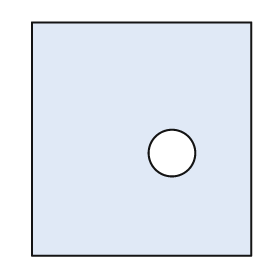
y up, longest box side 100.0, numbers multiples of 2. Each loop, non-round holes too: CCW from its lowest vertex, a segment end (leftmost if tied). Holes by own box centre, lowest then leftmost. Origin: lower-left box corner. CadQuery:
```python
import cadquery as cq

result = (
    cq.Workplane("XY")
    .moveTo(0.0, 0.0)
    .lineTo(94.0, 0.0)
    .lineTo(94.0, 100.0)
    .lineTo(0.0, 100.0)
    .close()
    .moveTo(60.0, 44.0)
    .circle(10.0)
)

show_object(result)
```